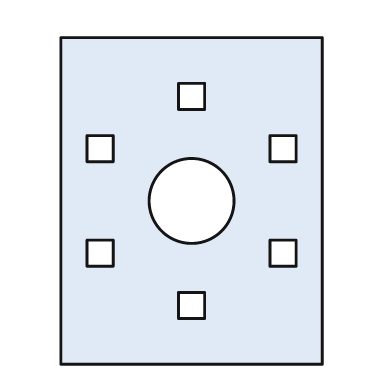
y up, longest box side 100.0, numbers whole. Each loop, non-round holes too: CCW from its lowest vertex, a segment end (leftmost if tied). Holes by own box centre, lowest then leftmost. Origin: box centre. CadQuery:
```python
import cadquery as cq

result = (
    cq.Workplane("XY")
    .moveTo(-40.0, -50.0)
    .lineTo(40.0, -50.0)
    .lineTo(40.0, 50.0)
    .lineTo(-40.0, 50.0)
    .close()
    .moveTo(-4.0, -36.0)
    .lineTo(4.0, -36.0)
    .lineTo(4.0, -28.0)
    .lineTo(-4.0, -28.0)
    .close()
    .moveTo(-32.0, -20.0)
    .lineTo(-24.0, -20.0)
    .lineTo(-24.0, -12.0)
    .lineTo(-32.0, -12.0)
    .close()
    .moveTo(24.0, -20.0)
    .lineTo(32.0, -20.0)
    .lineTo(32.0, -12.0)
    .lineTo(24.0, -12.0)
    .close()
    .moveTo(0.0, 0.0)
    .circle(13.0)
    .moveTo(-32.0, 12.0)
    .lineTo(-24.0, 12.0)
    .lineTo(-24.0, 20.0)
    .lineTo(-32.0, 20.0)
    .close()
    .moveTo(24.0, 12.0)
    .lineTo(32.0, 12.0)
    .lineTo(32.0, 20.0)
    .lineTo(24.0, 20.0)
    .close()
    .moveTo(-4.0, 28.0)
    .lineTo(4.0, 28.0)
    .lineTo(4.0, 36.0)
    .lineTo(-4.0, 36.0)
    .close()
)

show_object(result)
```